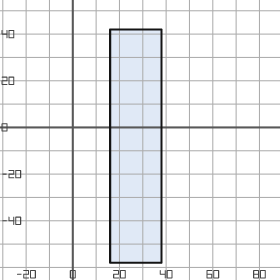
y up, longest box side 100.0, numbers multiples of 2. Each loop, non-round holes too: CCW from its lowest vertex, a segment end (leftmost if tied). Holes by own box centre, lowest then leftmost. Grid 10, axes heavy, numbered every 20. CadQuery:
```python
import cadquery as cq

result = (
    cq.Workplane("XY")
    .moveTo(16.0, -58.0)
    .lineTo(38.0, -58.0)
    .lineTo(38.0, 42.0)
    .lineTo(16.0, 42.0)
    .close()
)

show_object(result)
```